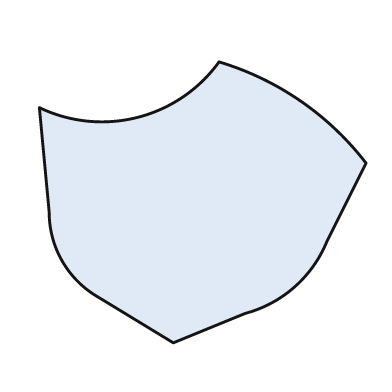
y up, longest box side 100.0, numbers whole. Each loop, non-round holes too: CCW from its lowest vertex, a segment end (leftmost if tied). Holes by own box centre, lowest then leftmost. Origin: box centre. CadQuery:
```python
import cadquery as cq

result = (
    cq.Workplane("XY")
    .moveTo(-9.0, -43.0)
    .lineTo(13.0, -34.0)
    .threePointArc((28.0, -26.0), (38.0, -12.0))
    .lineTo(50.0, 12.0)
    .threePointArc((30.0, 31.0), (5.0, 43.0))
    .threePointArc((-20.0, 26.0), (-50.0, 29.0))
    .lineTo(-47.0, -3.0)
    .threePointArc((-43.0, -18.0), (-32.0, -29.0))
    .close()
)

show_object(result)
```